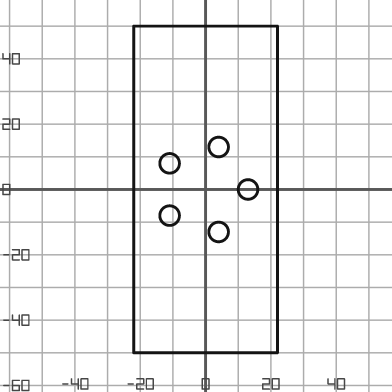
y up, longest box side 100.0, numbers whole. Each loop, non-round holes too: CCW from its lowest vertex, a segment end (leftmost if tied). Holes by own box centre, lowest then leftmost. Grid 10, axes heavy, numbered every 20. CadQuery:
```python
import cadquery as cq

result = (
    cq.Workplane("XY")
    .moveTo(-22.0, -50.0)
    .lineTo(22.0, -50.0)
    .lineTo(22.0, 50.0)
    .lineTo(-22.0, 50.0)
    .close()
    .moveTo(4.0, -13.0)
    .circle(3.0)
    .moveTo(-11.0, -8.0)
    .circle(3.0)
    .moveTo(13.0, 0.0)
    .circle(3.0)
    .moveTo(-11.0, 8.0)
    .circle(3.0)
    .moveTo(4.0, 13.0)
    .circle(3.0)
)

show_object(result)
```